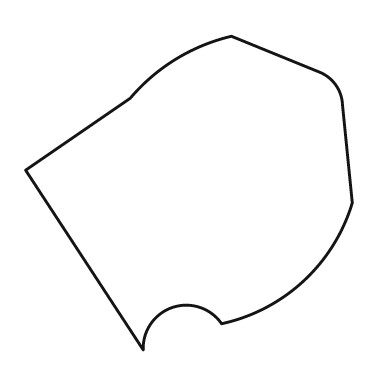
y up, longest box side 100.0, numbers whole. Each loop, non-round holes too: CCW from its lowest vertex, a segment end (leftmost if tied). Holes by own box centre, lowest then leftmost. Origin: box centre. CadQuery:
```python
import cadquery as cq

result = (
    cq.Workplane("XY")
    .moveTo(-14.0, -48.0)
    .threePointArc((-5.0, -35.0), (10.0, -40.0))
    .threePointArc((35.0, -27.0), (50.0, -3.0))
    .lineTo(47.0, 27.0)
    .threePointArc((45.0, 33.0), (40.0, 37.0))
    .lineTo(13.0, 48.0)
    .threePointArc((-4.0, 41.0), (-18.0, 29.0))
    .lineTo(-50.0, 7.0)
    .close()
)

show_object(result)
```